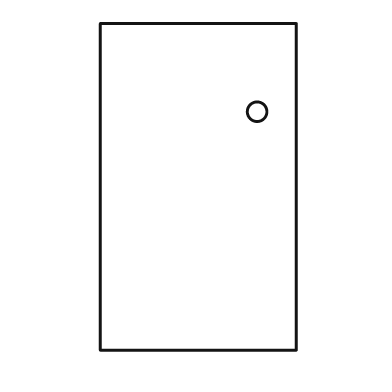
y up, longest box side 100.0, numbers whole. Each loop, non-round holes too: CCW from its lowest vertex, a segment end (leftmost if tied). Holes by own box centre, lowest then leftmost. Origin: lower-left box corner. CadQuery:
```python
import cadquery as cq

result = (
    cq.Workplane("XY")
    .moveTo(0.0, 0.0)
    .lineTo(60.0, 0.0)
    .lineTo(60.0, 100.0)
    .lineTo(0.0, 100.0)
    .close()
    .moveTo(48.0, 73.0)
    .circle(3.0)
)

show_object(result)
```